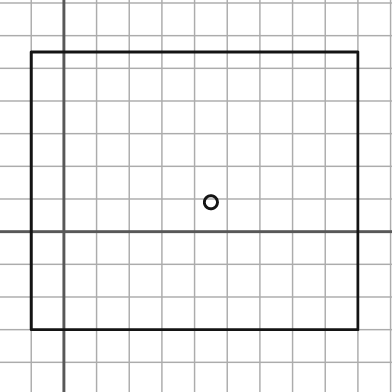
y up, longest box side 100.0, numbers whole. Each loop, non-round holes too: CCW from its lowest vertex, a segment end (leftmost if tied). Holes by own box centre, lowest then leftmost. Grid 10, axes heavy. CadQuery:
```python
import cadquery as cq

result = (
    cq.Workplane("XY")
    .moveTo(-10.0, -30.0)
    .lineTo(90.0, -30.0)
    .lineTo(90.0, 55.0)
    .lineTo(-10.0, 55.0)
    .close()
    .moveTo(45.0, 9.0)
    .circle(2.0)
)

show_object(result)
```